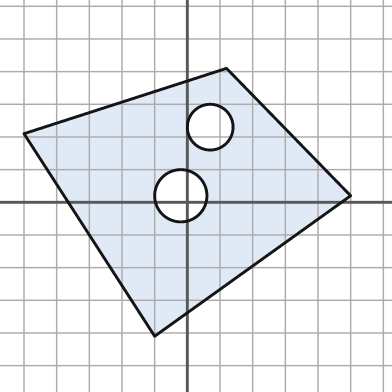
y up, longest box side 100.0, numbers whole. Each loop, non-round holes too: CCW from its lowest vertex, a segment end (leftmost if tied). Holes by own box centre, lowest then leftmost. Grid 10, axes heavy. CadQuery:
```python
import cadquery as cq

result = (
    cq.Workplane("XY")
    .moveTo(-10.0, -41.0)
    .lineTo(50.0, 2.0)
    .lineTo(12.0, 41.0)
    .lineTo(-50.0, 21.0)
    .close()
    .moveTo(-2.0, 2.0)
    .circle(8.0)
    .moveTo(7.0, 23.0)
    .circle(7.0)
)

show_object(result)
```